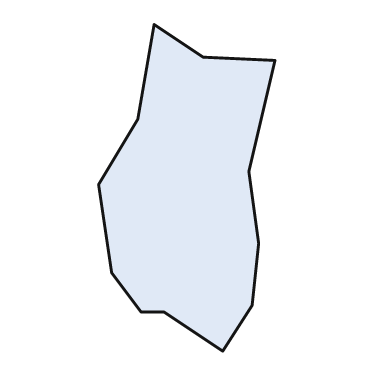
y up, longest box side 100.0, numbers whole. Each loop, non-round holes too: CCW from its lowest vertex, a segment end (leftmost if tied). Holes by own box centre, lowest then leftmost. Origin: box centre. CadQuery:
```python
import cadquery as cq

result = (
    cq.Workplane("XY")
    .moveTo(11.0, -50.0)
    .lineTo(20.0, -36.0)
    .lineTo(22.0, -17.0)
    .lineTo(19.0, 5.0)
    .lineTo(27.0, 39.0)
    .lineTo(5.0, 40.0)
    .lineTo(-10.0, 50.0)
    .lineTo(-15.0, 21.0)
    .lineTo(-27.0, 1.0)
    .lineTo(-23.0, -26.0)
    .lineTo(-14.0, -38.0)
    .lineTo(-7.0, -38.0)
    .close()
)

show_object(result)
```